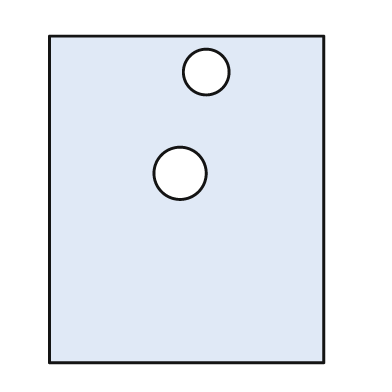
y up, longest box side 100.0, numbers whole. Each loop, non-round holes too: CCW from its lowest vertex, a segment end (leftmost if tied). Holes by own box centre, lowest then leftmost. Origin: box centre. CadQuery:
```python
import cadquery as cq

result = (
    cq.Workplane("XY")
    .moveTo(-42.0, -50.0)
    .lineTo(42.0, -50.0)
    .lineTo(42.0, 50.0)
    .lineTo(-42.0, 50.0)
    .close()
    .moveTo(-2.0, 8.0)
    .circle(8.0)
    .moveTo(6.0, 39.0)
    .circle(7.0)
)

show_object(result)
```